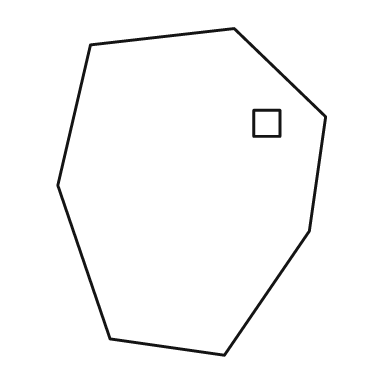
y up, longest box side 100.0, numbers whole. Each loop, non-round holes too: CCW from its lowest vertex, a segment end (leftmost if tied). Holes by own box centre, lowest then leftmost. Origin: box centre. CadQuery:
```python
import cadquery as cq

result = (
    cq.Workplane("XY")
    .moveTo(10.0, -50.0)
    .lineTo(36.0, -12.0)
    .lineTo(41.0, 23.0)
    .lineTo(13.0, 50.0)
    .lineTo(-31.0, 45.0)
    .lineTo(-41.0, 2.0)
    .lineTo(-25.0, -45.0)
    .close()
    .moveTo(19.0, 17.0)
    .lineTo(27.0, 17.0)
    .lineTo(27.0, 25.0)
    .lineTo(19.0, 25.0)
    .close()
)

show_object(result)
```